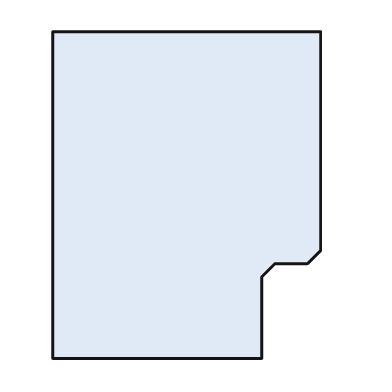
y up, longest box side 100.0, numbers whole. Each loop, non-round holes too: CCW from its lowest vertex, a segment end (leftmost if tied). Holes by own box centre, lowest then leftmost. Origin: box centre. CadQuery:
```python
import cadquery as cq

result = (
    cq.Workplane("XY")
    .moveTo(-41.0, -50.0)
    .lineTo(23.0, -50.0)
    .lineTo(23.0, -25.0)
    .lineTo(27.0, -21.0)
    .lineTo(37.0, -21.0)
    .lineTo(41.0, -17.0)
    .lineTo(41.0, 50.0)
    .lineTo(-41.0, 50.0)
    .close()
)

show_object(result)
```